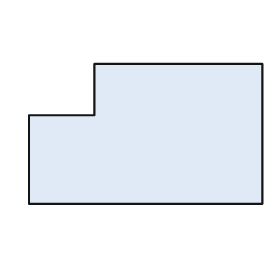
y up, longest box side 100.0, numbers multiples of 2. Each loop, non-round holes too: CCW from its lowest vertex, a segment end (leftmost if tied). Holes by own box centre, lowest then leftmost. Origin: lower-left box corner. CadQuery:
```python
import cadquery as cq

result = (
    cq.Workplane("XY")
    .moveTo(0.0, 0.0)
    .lineTo(100.0, 0.0)
    .lineTo(100.0, 60.0)
    .lineTo(28.0, 60.0)
    .lineTo(28.0, 38.0)
    .lineTo(0.0, 38.0)
    .close()
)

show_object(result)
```